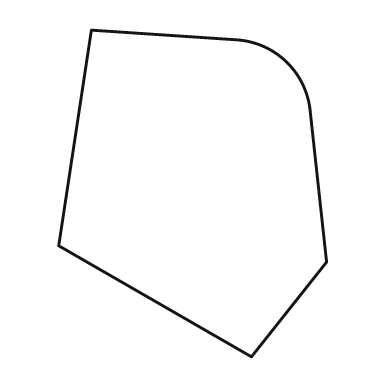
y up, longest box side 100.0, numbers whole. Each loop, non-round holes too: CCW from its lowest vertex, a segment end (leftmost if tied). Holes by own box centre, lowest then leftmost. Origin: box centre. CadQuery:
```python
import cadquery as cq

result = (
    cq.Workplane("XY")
    .moveTo(18.0, -50.0)
    .lineTo(41.0, -21.0)
    .lineTo(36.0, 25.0)
    .threePointArc((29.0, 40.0), (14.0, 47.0))
    .lineTo(-31.0, 50.0)
    .lineTo(-41.0, -16.0)
    .close()
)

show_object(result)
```